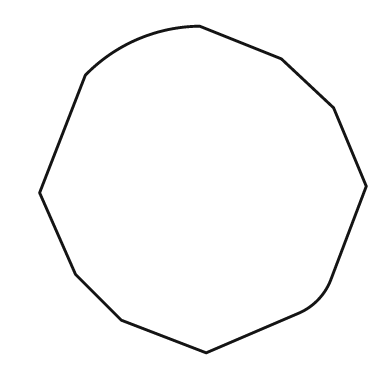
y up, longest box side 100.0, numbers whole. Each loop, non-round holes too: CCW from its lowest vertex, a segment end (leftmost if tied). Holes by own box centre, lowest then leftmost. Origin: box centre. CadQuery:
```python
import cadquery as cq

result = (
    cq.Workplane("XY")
    .moveTo(1.0, -50.0)
    .lineTo(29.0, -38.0)
    .threePointArc((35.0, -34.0), (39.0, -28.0))
    .lineTo(50.0, 1.0)
    .lineTo(40.0, 25.0)
    .lineTo(24.0, 40.0)
    .lineTo(-1.0, 50.0)
    .threePointArc((-20.0, 46.0), (-36.0, 35.0))
    .lineTo(-50.0, -1.0)
    .lineTo(-39.0, -26.0)
    .lineTo(-25.0, -40.0)
    .close()
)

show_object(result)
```